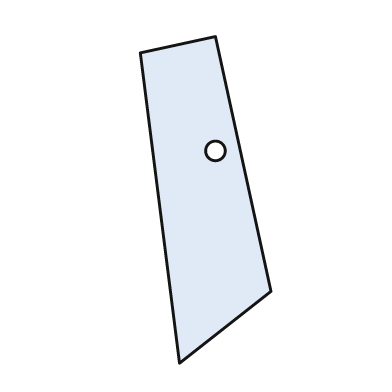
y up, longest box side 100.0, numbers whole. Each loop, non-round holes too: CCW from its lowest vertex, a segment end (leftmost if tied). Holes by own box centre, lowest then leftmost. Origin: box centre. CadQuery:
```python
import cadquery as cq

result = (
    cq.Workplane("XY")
    .moveTo(-8.0, -50.0)
    .lineTo(20.0, -28.0)
    .lineTo(3.0, 50.0)
    .lineTo(-20.0, 45.0)
    .close()
    .moveTo(3.0, 15.0)
    .circle(3.0)
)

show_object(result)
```